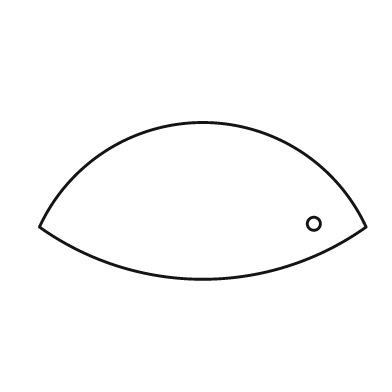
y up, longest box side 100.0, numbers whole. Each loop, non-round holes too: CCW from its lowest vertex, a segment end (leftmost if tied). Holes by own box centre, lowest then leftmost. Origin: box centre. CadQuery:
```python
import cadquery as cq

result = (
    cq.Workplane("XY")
    .moveTo(-50.0, -8.0)
    .threePointArc((0.0, -24.0), (50.0, -8.0))
    .threePointArc((0.0, 24.0), (-50.0, -8.0))
    .close()
    .moveTo(34.0, -7.0)
    .circle(2.0)
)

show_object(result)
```